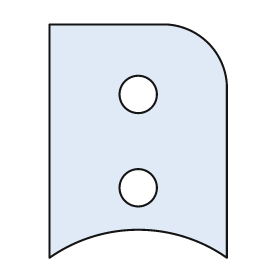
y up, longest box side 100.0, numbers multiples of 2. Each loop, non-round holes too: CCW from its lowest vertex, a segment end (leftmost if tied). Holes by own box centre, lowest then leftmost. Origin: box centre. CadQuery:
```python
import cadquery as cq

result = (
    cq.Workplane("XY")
    .moveTo(-38.0, -50.0)
    .threePointArc((0.0, -38.0), (38.0, -50.0))
    .lineTo(38.0, 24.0)
    .threePointArc((30.0, 42.0), (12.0, 50.0))
    .lineTo(-38.0, 50.0)
    .close()
    .moveTo(0.0, -20.0)
    .circle(8.0)
    .moveTo(0.0, 20.0)
    .circle(8.0)
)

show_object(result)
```